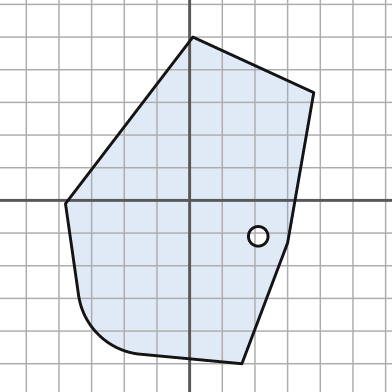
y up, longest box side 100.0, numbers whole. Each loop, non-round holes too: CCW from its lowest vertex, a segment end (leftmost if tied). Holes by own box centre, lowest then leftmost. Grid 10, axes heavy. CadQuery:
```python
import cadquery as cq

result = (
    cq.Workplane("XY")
    .moveTo(16.0, -50.0)
    .lineTo(30.0, -13.0)
    .lineTo(38.0, 33.0)
    .lineTo(1.0, 50.0)
    .lineTo(-38.0, -1.0)
    .lineTo(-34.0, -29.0)
    .threePointArc((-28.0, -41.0), (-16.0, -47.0))
    .close()
    .moveTo(21.0, -11.0)
    .circle(3.0)
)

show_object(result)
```